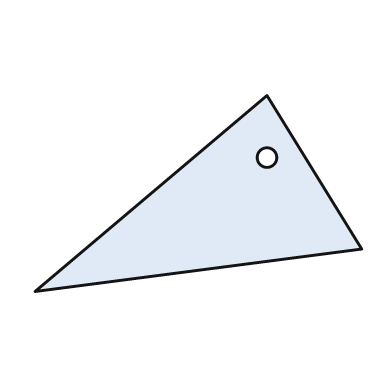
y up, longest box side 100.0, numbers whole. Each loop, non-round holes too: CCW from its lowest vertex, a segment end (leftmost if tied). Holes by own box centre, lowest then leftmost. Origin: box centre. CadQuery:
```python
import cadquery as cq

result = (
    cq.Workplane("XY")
    .moveTo(-50.0, -30.0)
    .lineTo(50.0, -17.0)
    .lineTo(21.0, 30.0)
    .close()
    .moveTo(21.0, 11.0)
    .circle(3.0)
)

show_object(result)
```